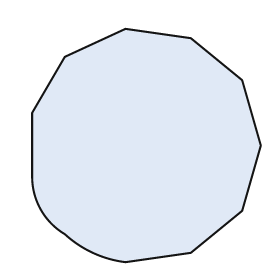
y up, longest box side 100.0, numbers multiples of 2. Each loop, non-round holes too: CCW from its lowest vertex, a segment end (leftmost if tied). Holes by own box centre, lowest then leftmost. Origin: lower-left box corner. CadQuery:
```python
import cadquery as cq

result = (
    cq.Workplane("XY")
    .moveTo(40.0, 0.0)
    .lineTo(68.0, 4.0)
    .lineTo(90.0, 22.0)
    .lineTo(98.0, 50.0)
    .lineTo(90.0, 78.0)
    .lineTo(68.0, 96.0)
    .lineTo(40.0, 100.0)
    .lineTo(14.0, 88.0)
    .lineTo(0.0, 64.0)
    .lineTo(0.0, 36.0)
    .threePointArc((4.0, 22.0), (14.0, 12.0))
    .threePointArc((26.0, 4.0), (40.0, 0.0))
    .close()
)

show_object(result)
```